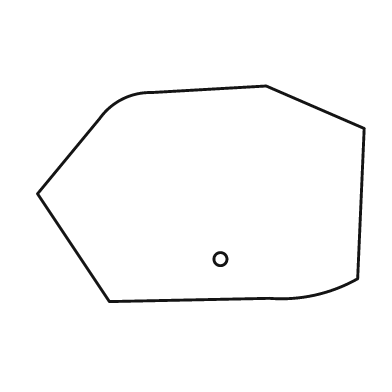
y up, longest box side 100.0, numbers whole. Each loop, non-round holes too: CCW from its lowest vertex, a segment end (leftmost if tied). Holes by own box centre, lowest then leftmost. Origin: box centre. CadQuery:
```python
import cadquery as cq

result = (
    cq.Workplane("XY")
    .moveTo(-28.0, -33.0)
    .lineTo(21.0, -32.0)
    .threePointArc((35.0, -31.0), (48.0, -26.0))
    .lineTo(50.0, 20.0)
    .lineTo(20.0, 33.0)
    .lineTo(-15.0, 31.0)
    .threePointArc((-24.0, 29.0), (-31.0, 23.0))
    .lineTo(-50.0, 0.0)
    .close()
    .moveTo(6.0, -20.0)
    .circle(2.0)
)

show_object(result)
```